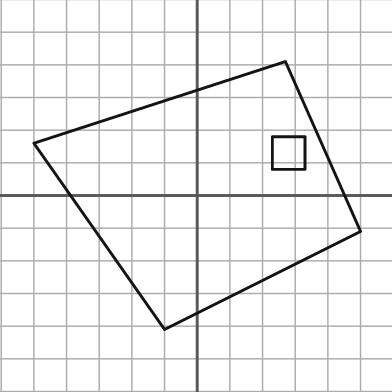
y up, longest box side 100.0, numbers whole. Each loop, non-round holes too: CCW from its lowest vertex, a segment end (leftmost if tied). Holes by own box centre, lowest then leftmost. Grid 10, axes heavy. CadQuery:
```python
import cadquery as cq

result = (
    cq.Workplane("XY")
    .moveTo(-10.0, -41.0)
    .lineTo(50.0, -11.0)
    .lineTo(27.0, 41.0)
    .lineTo(-50.0, 16.0)
    .close()
    .moveTo(23.0, 8.0)
    .lineTo(33.0, 8.0)
    .lineTo(33.0, 18.0)
    .lineTo(23.0, 18.0)
    .close()
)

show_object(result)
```